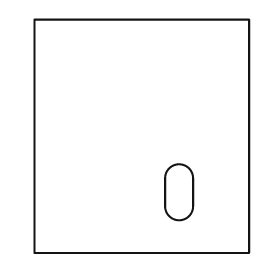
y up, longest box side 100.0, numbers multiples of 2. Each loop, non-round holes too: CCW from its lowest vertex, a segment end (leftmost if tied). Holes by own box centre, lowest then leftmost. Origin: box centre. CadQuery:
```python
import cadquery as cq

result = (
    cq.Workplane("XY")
    .moveTo(-46.0, -50.0)
    .lineTo(46.0, -50.0)
    .lineTo(46.0, 50.0)
    .lineTo(-46.0, 50.0)
    .close()
    .moveTo(10.0, -30.0)
    .threePointArc((16.0, -36.0), (22.0, -30.0))
    .lineTo(22.0, -18.0)
    .threePointArc((16.0, -12.0), (10.0, -18.0))
    .close()
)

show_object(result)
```